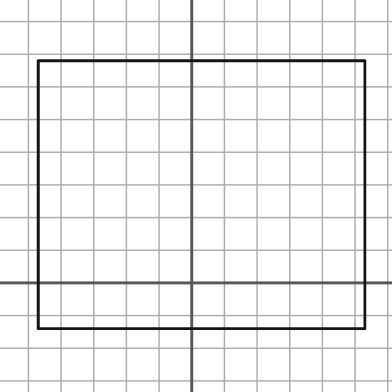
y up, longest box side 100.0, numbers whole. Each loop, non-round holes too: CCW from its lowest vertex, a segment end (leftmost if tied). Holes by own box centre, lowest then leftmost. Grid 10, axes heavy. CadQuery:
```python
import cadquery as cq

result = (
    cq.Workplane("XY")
    .moveTo(-47.0, -14.0)
    .lineTo(53.0, -14.0)
    .lineTo(53.0, 68.0)
    .lineTo(-47.0, 68.0)
    .close()
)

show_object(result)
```